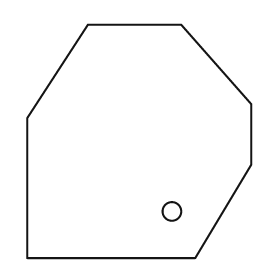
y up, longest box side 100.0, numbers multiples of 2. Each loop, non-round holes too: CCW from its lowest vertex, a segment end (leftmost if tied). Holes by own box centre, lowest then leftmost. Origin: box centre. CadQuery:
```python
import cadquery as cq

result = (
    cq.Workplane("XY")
    .moveTo(-48.0, -50.0)
    .lineTo(24.0, -50.0)
    .lineTo(48.0, -10.0)
    .lineTo(48.0, 16.0)
    .lineTo(18.0, 50.0)
    .lineTo(-22.0, 50.0)
    .lineTo(-48.0, 10.0)
    .close()
    .moveTo(14.0, -30.0)
    .circle(4.0)
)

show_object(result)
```